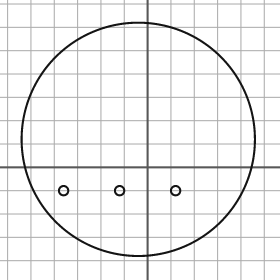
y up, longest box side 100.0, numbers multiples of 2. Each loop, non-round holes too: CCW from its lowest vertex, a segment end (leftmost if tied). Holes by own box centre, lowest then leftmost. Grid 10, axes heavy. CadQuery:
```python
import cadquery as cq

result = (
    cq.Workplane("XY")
    .moveTo(-4.0, 12.0)
    .circle(50.0)
    .moveTo(-36.0, -10.0)
    .circle(2.0)
    .moveTo(-12.0, -10.0)
    .circle(2.0)
    .moveTo(12.0, -10.0)
    .circle(2.0)
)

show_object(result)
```